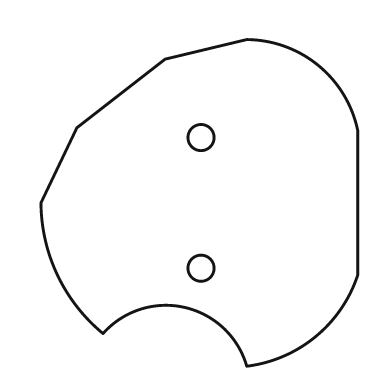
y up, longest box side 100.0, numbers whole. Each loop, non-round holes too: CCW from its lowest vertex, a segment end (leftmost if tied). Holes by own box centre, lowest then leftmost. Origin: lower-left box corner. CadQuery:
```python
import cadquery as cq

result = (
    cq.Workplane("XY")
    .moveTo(63.0, 0.0)
    .threePointArc((84.0, 9.0), (97.0, 28.0))
    .lineTo(97.0, 72.0)
    .threePointArc((85.0, 92.0), (63.0, 100.0))
    .lineTo(38.0, 94.0)
    .lineTo(11.0, 73.0)
    .lineTo(0.0, 50.0)
    .threePointArc((5.0, 28.0), (19.0, 10.0))
    .threePointArc((44.0, 18.0), (63.0, 0.0))
    .close()
    .moveTo(49.0, 30.0)
    .circle(4.0)
    .moveTo(49.0, 70.0)
    .circle(4.0)
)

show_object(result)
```